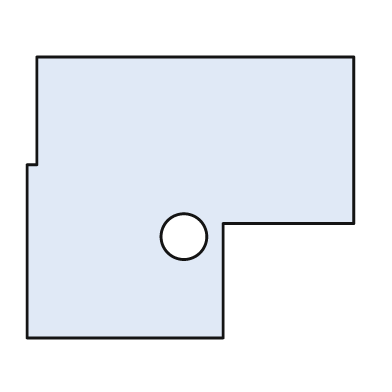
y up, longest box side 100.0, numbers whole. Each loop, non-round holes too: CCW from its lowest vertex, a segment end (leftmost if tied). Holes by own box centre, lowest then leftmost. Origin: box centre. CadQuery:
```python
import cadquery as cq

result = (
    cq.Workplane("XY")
    .moveTo(-50.0, -43.0)
    .lineTo(10.0, -43.0)
    .lineTo(10.0, -8.0)
    .lineTo(50.0, -8.0)
    .lineTo(50.0, 43.0)
    .lineTo(-47.0, 43.0)
    .lineTo(-47.0, 10.0)
    .lineTo(-50.0, 10.0)
    .close()
    .moveTo(-2.0, -12.0)
    .circle(7.0)
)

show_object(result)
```